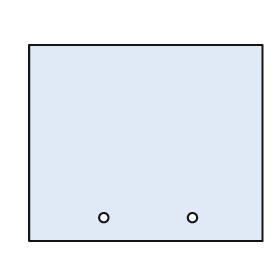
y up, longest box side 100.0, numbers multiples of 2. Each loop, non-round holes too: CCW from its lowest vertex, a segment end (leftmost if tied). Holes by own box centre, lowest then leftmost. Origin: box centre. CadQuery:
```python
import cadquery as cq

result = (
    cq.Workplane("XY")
    .moveTo(-50.0, -42.0)
    .lineTo(50.0, -42.0)
    .lineTo(50.0, 42.0)
    .lineTo(-50.0, 42.0)
    .close()
    .moveTo(-18.0, -32.0)
    .circle(2.0)
    .moveTo(20.0, -32.0)
    .circle(2.0)
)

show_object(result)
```